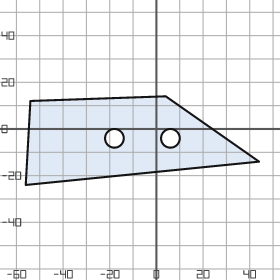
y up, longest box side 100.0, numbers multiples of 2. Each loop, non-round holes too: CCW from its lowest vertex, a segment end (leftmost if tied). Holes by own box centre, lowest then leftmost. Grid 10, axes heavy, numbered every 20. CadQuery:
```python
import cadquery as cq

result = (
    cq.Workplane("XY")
    .moveTo(-56.0, -24.0)
    .lineTo(44.0, -14.0)
    .lineTo(4.0, 14.0)
    .lineTo(-54.0, 12.0)
    .close()
    .moveTo(-18.0, -4.0)
    .circle(4.0)
    .moveTo(6.0, -4.0)
    .circle(4.0)
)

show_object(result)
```